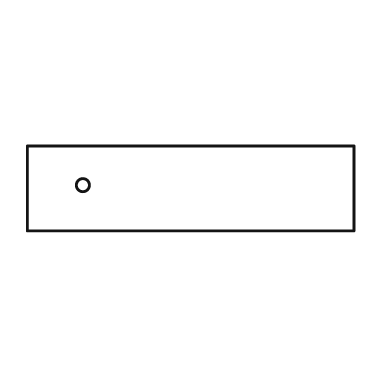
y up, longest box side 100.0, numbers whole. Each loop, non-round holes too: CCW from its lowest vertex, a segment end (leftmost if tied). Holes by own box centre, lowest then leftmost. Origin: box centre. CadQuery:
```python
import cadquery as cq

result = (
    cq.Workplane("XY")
    .moveTo(-50.0, -13.0)
    .lineTo(50.0, -13.0)
    .lineTo(50.0, 13.0)
    .lineTo(-50.0, 13.0)
    .close()
    .moveTo(-33.0, 1.0)
    .circle(2.0)
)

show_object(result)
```